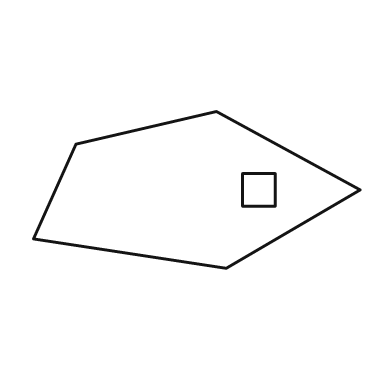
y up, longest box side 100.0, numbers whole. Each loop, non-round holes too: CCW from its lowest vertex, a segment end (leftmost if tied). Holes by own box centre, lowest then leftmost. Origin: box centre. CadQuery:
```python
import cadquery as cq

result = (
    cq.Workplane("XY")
    .moveTo(9.0, -24.0)
    .lineTo(50.0, 0.0)
    .lineTo(6.0, 24.0)
    .lineTo(-37.0, 14.0)
    .lineTo(-50.0, -15.0)
    .close()
    .moveTo(14.0, -5.0)
    .lineTo(24.0, -5.0)
    .lineTo(24.0, 5.0)
    .lineTo(14.0, 5.0)
    .close()
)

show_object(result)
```